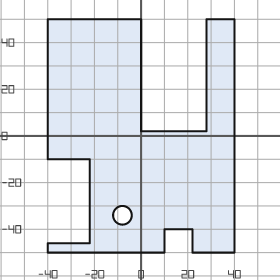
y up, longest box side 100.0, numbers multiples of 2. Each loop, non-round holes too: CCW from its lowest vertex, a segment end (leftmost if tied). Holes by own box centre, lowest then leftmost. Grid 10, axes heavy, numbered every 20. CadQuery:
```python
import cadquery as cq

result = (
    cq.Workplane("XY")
    .moveTo(-40.0, -50.0)
    .lineTo(10.0, -50.0)
    .lineTo(10.0, -40.0)
    .lineTo(22.0, -40.0)
    .lineTo(22.0, -50.0)
    .lineTo(40.0, -50.0)
    .lineTo(40.0, 50.0)
    .lineTo(28.0, 50.0)
    .lineTo(28.0, 2.0)
    .lineTo(0.0, 2.0)
    .lineTo(0.0, 50.0)
    .lineTo(-40.0, 50.0)
    .lineTo(-40.0, -10.0)
    .lineTo(-22.0, -10.0)
    .lineTo(-22.0, -46.0)
    .lineTo(-40.0, -46.0)
    .close()
    .moveTo(-8.0, -34.0)
    .circle(4.0)
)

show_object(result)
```